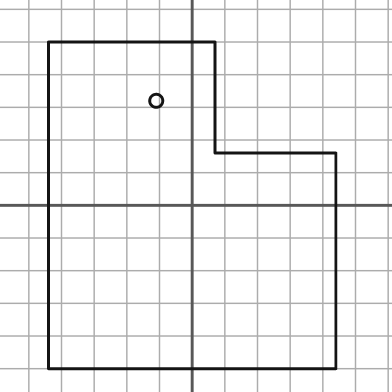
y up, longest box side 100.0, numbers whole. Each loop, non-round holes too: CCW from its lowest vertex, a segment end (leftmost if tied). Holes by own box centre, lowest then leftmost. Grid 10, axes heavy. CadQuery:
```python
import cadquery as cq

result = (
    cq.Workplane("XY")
    .moveTo(-44.0, -50.0)
    .lineTo(44.0, -50.0)
    .lineTo(44.0, 16.0)
    .lineTo(7.0, 16.0)
    .lineTo(7.0, 50.0)
    .lineTo(-44.0, 50.0)
    .close()
    .moveTo(-11.0, 32.0)
    .circle(2.0)
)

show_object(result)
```